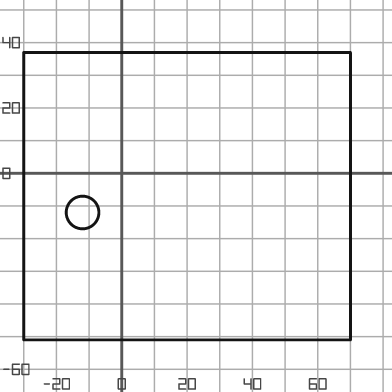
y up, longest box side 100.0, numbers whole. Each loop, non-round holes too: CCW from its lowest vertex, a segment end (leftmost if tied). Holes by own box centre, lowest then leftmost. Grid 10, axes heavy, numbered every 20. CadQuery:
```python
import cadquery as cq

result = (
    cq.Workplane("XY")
    .moveTo(-30.0, -51.0)
    .lineTo(70.0, -51.0)
    .lineTo(70.0, 37.0)
    .lineTo(-30.0, 37.0)
    .close()
    .moveTo(-12.0, -12.0)
    .circle(5.0)
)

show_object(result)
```